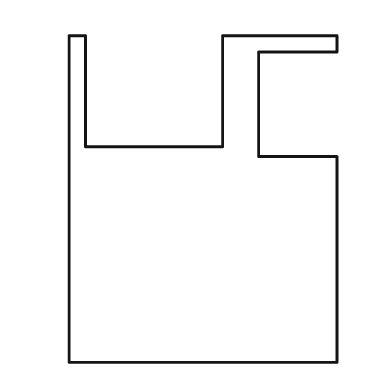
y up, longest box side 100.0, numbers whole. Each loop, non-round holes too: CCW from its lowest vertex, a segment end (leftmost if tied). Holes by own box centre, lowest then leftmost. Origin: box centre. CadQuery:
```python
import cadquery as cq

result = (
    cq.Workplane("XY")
    .moveTo(-41.0, -50.0)
    .lineTo(41.0, -50.0)
    .lineTo(41.0, 13.0)
    .lineTo(17.0, 13.0)
    .lineTo(17.0, 45.0)
    .lineTo(41.0, 45.0)
    .lineTo(41.0, 50.0)
    .lineTo(6.0, 50.0)
    .lineTo(6.0, 16.0)
    .lineTo(-36.0, 16.0)
    .lineTo(-36.0, 50.0)
    .lineTo(-41.0, 50.0)
    .close()
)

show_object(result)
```